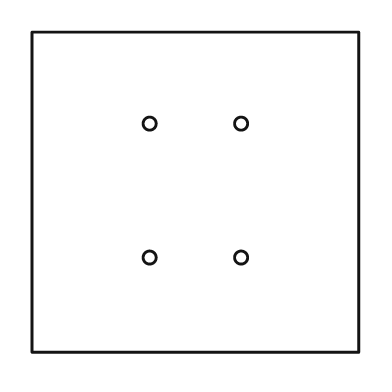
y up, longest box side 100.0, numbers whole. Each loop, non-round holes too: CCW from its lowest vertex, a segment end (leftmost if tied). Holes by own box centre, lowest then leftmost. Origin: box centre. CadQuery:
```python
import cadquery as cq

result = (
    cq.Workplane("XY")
    .moveTo(-50.0, -49.0)
    .lineTo(50.0, -49.0)
    .lineTo(50.0, 49.0)
    .lineTo(-50.0, 49.0)
    .close()
    .moveTo(-14.0, -20.0)
    .circle(2.0)
    .moveTo(14.0, -20.0)
    .circle(2.0)
    .moveTo(-14.0, 21.0)
    .circle(2.0)
    .moveTo(14.0, 21.0)
    .circle(2.0)
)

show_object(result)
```